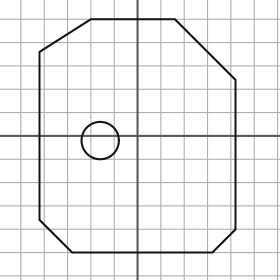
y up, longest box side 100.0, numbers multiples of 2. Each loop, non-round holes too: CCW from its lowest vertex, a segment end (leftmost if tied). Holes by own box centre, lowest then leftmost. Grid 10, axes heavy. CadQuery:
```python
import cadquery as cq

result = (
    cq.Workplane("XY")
    .moveTo(-28.0, -50.0)
    .lineTo(32.0, -50.0)
    .lineTo(42.0, -40.0)
    .lineTo(42.0, 24.0)
    .lineTo(16.0, 50.0)
    .lineTo(-20.0, 50.0)
    .lineTo(-42.0, 36.0)
    .lineTo(-42.0, -36.0)
    .close()
    .moveTo(-16.0, -2.0)
    .circle(8.0)
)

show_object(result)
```